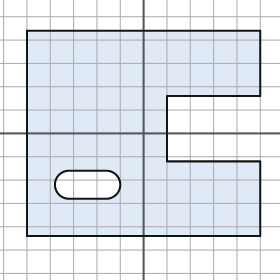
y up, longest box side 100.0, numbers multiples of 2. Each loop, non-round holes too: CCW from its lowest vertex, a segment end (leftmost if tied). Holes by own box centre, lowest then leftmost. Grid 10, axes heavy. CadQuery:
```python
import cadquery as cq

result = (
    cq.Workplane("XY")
    .moveTo(-50.0, -44.0)
    .lineTo(50.0, -44.0)
    .lineTo(50.0, -12.0)
    .lineTo(10.0, -12.0)
    .lineTo(10.0, 16.0)
    .lineTo(50.0, 16.0)
    .lineTo(50.0, 44.0)
    .lineTo(-50.0, 44.0)
    .close()
    .moveTo(-32.0, -28.0)
    .lineTo(-16.0, -28.0)
    .threePointArc((-10.0, -22.0), (-16.0, -16.0))
    .lineTo(-32.0, -16.0)
    .threePointArc((-38.0, -22.0), (-32.0, -28.0))
    .close()
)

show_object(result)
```